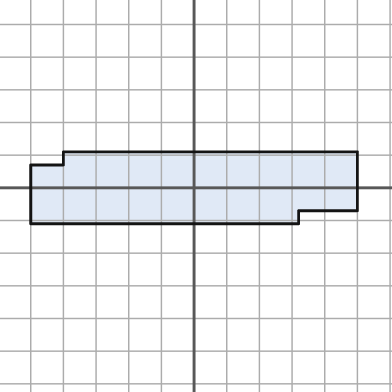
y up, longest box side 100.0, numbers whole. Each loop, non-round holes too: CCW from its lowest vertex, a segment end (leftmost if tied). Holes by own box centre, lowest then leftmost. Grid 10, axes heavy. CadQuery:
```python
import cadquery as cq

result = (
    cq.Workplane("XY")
    .moveTo(-50.0, -11.0)
    .lineTo(32.0, -11.0)
    .lineTo(32.0, -7.0)
    .lineTo(50.0, -7.0)
    .lineTo(50.0, 11.0)
    .lineTo(-40.0, 11.0)
    .lineTo(-40.0, 7.0)
    .lineTo(-50.0, 7.0)
    .close()
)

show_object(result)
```